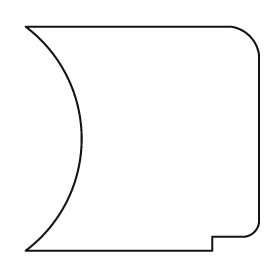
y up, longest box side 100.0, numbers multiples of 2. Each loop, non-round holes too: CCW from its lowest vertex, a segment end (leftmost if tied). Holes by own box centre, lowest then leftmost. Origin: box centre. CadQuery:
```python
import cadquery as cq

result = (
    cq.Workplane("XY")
    .moveTo(-50.0, -48.0)
    .lineTo(30.0, -48.0)
    .lineTo(30.0, -42.0)
    .lineTo(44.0, -42.0)
    .threePointArc((48.0, -40.0), (50.0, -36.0))
    .lineTo(50.0, 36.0)
    .threePointArc((46.0, 44.0), (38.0, 48.0))
    .lineTo(-50.0, 48.0)
    .threePointArc((-26.0, 0.0), (-50.0, -48.0))
    .close()
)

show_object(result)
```